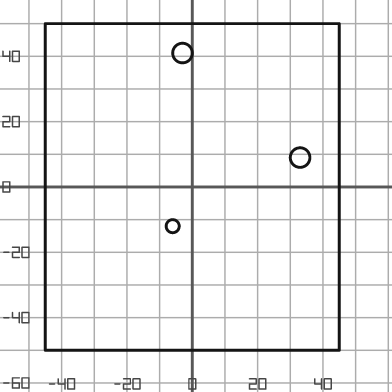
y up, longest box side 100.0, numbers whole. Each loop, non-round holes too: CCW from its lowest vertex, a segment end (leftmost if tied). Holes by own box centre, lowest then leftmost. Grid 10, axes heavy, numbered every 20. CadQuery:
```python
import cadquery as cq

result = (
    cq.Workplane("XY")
    .moveTo(-45.0, -50.0)
    .lineTo(45.0, -50.0)
    .lineTo(45.0, 50.0)
    .lineTo(-45.0, 50.0)
    .close()
    .moveTo(-6.0, -12.0)
    .circle(2.0)
    .moveTo(33.0, 9.0)
    .circle(3.0)
    .moveTo(-3.0, 41.0)
    .circle(3.0)
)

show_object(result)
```